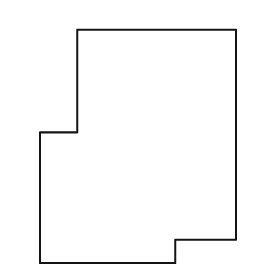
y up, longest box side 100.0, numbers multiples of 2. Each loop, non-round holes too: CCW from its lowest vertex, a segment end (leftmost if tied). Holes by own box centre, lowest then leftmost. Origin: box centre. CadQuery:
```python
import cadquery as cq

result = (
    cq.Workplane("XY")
    .moveTo(-42.0, -50.0)
    .lineTo(16.0, -50.0)
    .lineTo(16.0, -40.0)
    .lineTo(42.0, -40.0)
    .lineTo(42.0, 50.0)
    .lineTo(-26.0, 50.0)
    .lineTo(-26.0, 6.0)
    .lineTo(-42.0, 6.0)
    .close()
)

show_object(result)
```